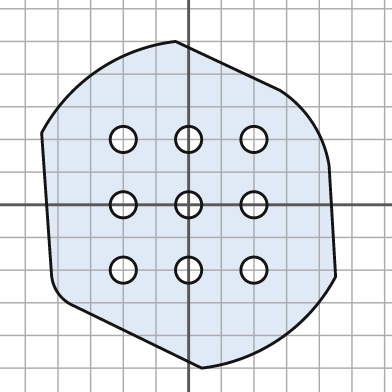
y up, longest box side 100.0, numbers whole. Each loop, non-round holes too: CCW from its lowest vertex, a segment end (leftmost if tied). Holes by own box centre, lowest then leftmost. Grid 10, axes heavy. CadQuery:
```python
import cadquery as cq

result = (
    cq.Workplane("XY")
    .moveTo(4.0, -50.0)
    .threePointArc((28.0, -41.0), (45.0, -22.0))
    .lineTo(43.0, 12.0)
    .threePointArc((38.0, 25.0), (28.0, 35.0))
    .lineTo(-4.0, 50.0)
    .threePointArc((-28.0, 41.0), (-45.0, 22.0))
    .lineTo(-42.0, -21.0)
    .threePointArc((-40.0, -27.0), (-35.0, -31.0))
    .close()
    .moveTo(-20.0, -20.0)
    .circle(4.0)
    .moveTo(0.0, -20.0)
    .circle(4.0)
    .moveTo(20.0, -20.0)
    .circle(4.0)
    .moveTo(-20.0, 0.0)
    .circle(4.0)
    .moveTo(0.0, 0.0)
    .circle(4.0)
    .moveTo(20.0, 0.0)
    .circle(4.0)
    .moveTo(-20.0, 20.0)
    .circle(4.0)
    .moveTo(0.0, 20.0)
    .circle(4.0)
    .moveTo(20.0, 20.0)
    .circle(4.0)
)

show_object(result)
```